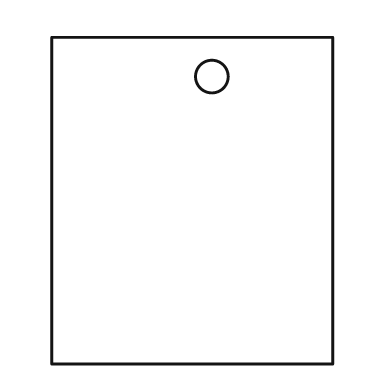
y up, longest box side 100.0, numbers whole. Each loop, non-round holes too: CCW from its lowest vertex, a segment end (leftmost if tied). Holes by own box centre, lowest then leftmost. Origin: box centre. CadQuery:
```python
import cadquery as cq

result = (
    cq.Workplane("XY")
    .moveTo(-43.0, -50.0)
    .lineTo(43.0, -50.0)
    .lineTo(43.0, 50.0)
    .lineTo(-43.0, 50.0)
    .close()
    .moveTo(6.0, 38.0)
    .circle(5.0)
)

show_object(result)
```